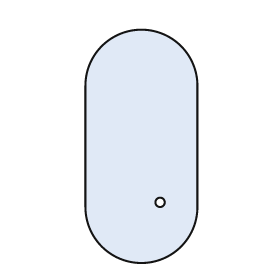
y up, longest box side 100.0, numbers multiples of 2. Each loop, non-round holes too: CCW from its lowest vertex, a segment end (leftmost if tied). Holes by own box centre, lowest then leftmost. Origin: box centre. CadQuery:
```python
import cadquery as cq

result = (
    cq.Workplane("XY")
    .moveTo(-24.0, -26.0)
    .threePointArc((0.0, -50.0), (24.0, -26.0))
    .lineTo(24.0, 26.0)
    .threePointArc((0.0, 50.0), (-24.0, 26.0))
    .close()
    .moveTo(8.0, -24.0)
    .circle(2.0)
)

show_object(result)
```